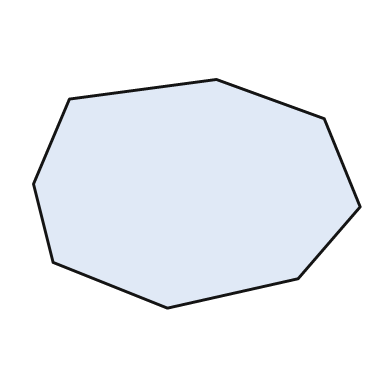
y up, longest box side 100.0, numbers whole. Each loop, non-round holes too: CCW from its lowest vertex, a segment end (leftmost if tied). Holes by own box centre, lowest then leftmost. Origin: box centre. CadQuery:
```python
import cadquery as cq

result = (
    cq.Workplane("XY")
    .moveTo(-9.0, -35.0)
    .lineTo(31.0, -26.0)
    .lineTo(50.0, -4.0)
    .lineTo(39.0, 23.0)
    .lineTo(6.0, 35.0)
    .lineTo(-39.0, 29.0)
    .lineTo(-50.0, 3.0)
    .lineTo(-44.0, -21.0)
    .close()
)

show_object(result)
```